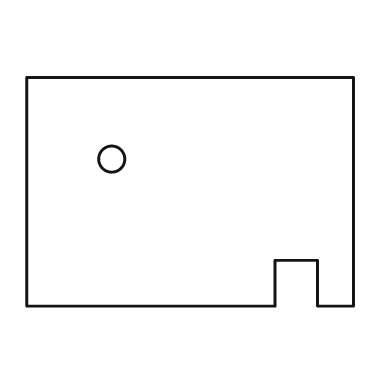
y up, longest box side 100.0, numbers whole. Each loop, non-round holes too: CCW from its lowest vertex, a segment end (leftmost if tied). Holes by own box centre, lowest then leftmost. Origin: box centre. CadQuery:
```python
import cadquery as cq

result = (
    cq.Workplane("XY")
    .moveTo(-50.0, -35.0)
    .lineTo(26.0, -35.0)
    .lineTo(26.0, -21.0)
    .lineTo(39.0, -21.0)
    .lineTo(39.0, -35.0)
    .lineTo(50.0, -35.0)
    .lineTo(50.0, 35.0)
    .lineTo(-50.0, 35.0)
    .close()
    .moveTo(-24.0, 10.0)
    .circle(4.0)
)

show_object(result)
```